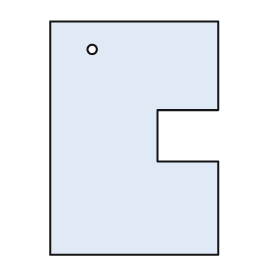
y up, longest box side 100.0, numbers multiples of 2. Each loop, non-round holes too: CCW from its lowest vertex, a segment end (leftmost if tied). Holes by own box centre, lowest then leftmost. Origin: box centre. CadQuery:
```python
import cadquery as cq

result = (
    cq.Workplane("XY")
    .moveTo(-36.0, -50.0)
    .lineTo(36.0, -50.0)
    .lineTo(36.0, -10.0)
    .lineTo(10.0, -10.0)
    .lineTo(10.0, 12.0)
    .lineTo(36.0, 12.0)
    .lineTo(36.0, 50.0)
    .lineTo(-36.0, 50.0)
    .close()
    .moveTo(-18.0, 38.0)
    .circle(2.0)
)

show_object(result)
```